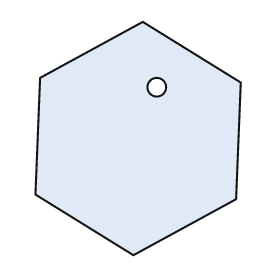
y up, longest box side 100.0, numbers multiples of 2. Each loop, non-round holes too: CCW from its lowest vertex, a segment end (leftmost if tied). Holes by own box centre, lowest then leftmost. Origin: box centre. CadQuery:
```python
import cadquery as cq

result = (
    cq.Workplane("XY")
    .moveTo(-2.0, -50.0)
    .lineTo(42.0, -26.0)
    .lineTo(44.0, 24.0)
    .lineTo(2.0, 50.0)
    .lineTo(-42.0, 26.0)
    .lineTo(-44.0, -24.0)
    .close()
    .moveTo(8.0, 22.0)
    .circle(4.0)
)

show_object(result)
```